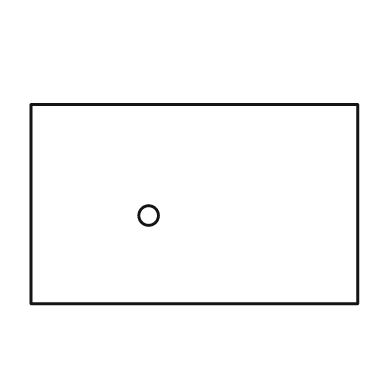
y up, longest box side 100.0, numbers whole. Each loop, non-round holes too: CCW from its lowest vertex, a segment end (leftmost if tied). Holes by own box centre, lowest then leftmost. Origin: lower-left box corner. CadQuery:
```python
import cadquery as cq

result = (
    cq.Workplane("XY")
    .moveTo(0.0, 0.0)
    .lineTo(100.0, 0.0)
    .lineTo(100.0, 61.0)
    .lineTo(0.0, 61.0)
    .close()
    .moveTo(36.0, 27.0)
    .circle(3.0)
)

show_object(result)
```